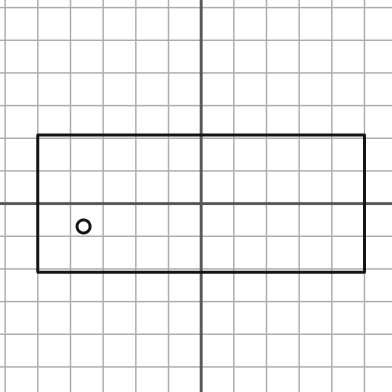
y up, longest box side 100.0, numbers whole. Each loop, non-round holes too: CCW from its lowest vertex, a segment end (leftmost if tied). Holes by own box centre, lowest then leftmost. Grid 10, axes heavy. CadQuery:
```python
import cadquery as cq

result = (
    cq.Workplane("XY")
    .moveTo(-50.0, -21.0)
    .lineTo(50.0, -21.0)
    .lineTo(50.0, 21.0)
    .lineTo(-50.0, 21.0)
    .close()
    .moveTo(-36.0, -7.0)
    .circle(2.0)
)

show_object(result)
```